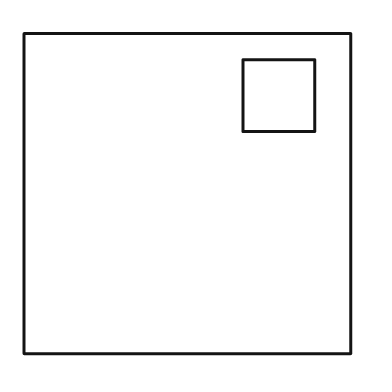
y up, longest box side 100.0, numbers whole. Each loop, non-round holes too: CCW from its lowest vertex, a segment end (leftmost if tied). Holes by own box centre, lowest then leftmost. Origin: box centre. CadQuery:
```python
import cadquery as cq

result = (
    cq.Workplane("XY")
    .moveTo(-50.0, -49.0)
    .lineTo(50.0, -49.0)
    .lineTo(50.0, 49.0)
    .lineTo(-50.0, 49.0)
    .close()
    .moveTo(17.0, 19.0)
    .lineTo(39.0, 19.0)
    .lineTo(39.0, 41.0)
    .lineTo(17.0, 41.0)
    .close()
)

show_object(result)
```